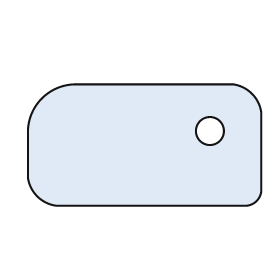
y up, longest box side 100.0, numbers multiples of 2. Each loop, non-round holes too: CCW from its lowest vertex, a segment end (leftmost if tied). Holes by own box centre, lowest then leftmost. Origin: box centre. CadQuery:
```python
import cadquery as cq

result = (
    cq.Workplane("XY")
    .moveTo(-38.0, -26.0)
    .lineTo(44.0, -26.0)
    .threePointArc((48.0, -24.0), (50.0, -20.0))
    .lineTo(50.0, 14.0)
    .threePointArc((46.0, 22.0), (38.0, 26.0))
    .lineTo(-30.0, 26.0)
    .threePointArc((-44.0, 20.0), (-50.0, 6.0))
    .lineTo(-50.0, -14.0)
    .threePointArc((-46.0, -22.0), (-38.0, -26.0))
    .close()
    .moveTo(28.0, 6.0)
    .circle(6.0)
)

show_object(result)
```